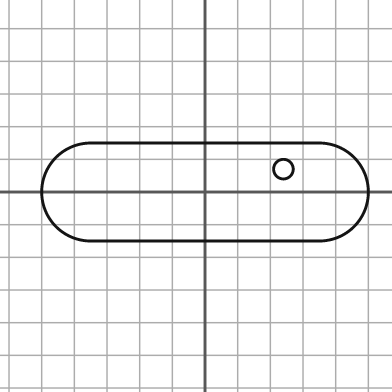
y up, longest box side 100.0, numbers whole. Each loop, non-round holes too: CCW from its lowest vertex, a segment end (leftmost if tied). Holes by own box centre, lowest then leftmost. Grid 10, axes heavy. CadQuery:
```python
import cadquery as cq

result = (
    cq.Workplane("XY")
    .moveTo(-35.0, -15.0)
    .lineTo(35.0, -15.0)
    .threePointArc((50.0, 0.0), (35.0, 15.0))
    .lineTo(-35.0, 15.0)
    .threePointArc((-50.0, 0.0), (-35.0, -15.0))
    .close()
    .moveTo(24.0, 7.0)
    .circle(3.0)
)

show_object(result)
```